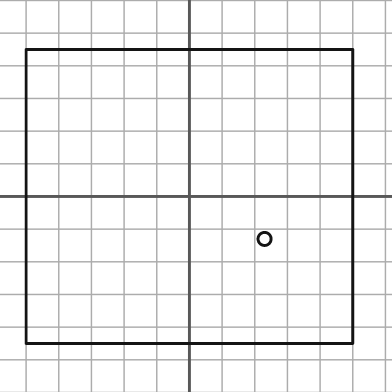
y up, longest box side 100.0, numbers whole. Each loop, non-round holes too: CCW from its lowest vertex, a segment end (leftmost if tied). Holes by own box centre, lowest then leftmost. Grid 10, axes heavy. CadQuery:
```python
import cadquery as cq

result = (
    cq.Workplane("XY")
    .moveTo(-50.0, -45.0)
    .lineTo(50.0, -45.0)
    .lineTo(50.0, 45.0)
    .lineTo(-50.0, 45.0)
    .close()
    .moveTo(23.0, -13.0)
    .circle(2.0)
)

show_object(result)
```